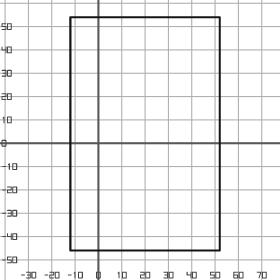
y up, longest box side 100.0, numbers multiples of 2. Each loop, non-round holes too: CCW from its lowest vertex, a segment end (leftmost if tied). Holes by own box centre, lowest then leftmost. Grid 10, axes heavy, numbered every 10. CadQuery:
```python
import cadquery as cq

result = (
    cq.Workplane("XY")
    .moveTo(-12.0, -46.0)
    .lineTo(52.0, -46.0)
    .lineTo(52.0, 54.0)
    .lineTo(-12.0, 54.0)
    .close()
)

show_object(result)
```